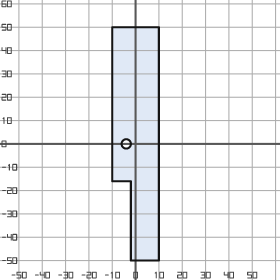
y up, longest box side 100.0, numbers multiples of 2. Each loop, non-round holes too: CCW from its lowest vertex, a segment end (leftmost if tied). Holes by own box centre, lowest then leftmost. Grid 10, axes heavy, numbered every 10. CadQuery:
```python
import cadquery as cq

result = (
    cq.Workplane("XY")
    .moveTo(-2.0, -50.0)
    .lineTo(10.0, -50.0)
    .lineTo(10.0, 50.0)
    .lineTo(-10.0, 50.0)
    .lineTo(-10.0, -16.0)
    .lineTo(-2.0, -16.0)
    .close()
    .moveTo(-4.0, 0.0)
    .circle(2.0)
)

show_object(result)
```